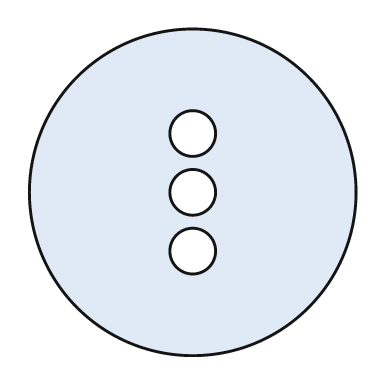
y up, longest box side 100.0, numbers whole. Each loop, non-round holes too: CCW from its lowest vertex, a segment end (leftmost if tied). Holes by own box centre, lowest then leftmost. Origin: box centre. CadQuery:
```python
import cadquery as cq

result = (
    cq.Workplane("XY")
    .moveTo(0.0, 0.0)
    .circle(50.0)
    .moveTo(0.0, -18.0)
    .circle(7.0)
    .moveTo(0.0, 0.0)
    .circle(7.0)
    .moveTo(0.0, 18.0)
    .circle(7.0)
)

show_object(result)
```